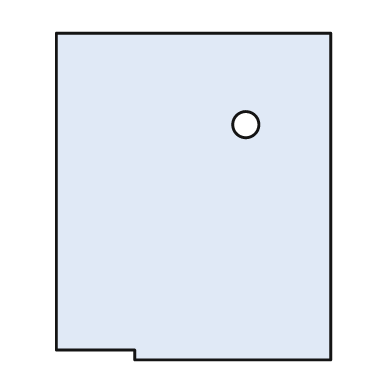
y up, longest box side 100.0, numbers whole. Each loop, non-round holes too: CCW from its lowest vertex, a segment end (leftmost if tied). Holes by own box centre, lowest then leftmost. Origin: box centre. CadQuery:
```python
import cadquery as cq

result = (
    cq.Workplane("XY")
    .moveTo(-18.0, -50.0)
    .lineTo(42.0, -50.0)
    .lineTo(42.0, 50.0)
    .lineTo(-42.0, 50.0)
    .lineTo(-42.0, -47.0)
    .lineTo(-18.0, -47.0)
    .close()
    .moveTo(16.0, 22.0)
    .circle(4.0)
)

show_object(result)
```